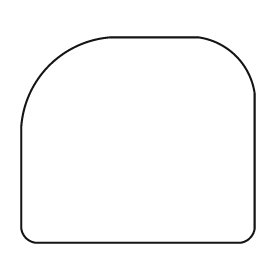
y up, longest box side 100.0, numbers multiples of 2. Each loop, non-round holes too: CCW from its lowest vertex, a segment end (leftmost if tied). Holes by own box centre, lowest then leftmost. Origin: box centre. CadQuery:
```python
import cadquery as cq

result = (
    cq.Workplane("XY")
    .moveTo(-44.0, -44.0)
    .lineTo(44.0, -44.0)
    .threePointArc((48.0, -42.0), (50.0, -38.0))
    .lineTo(50.0, 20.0)
    .threePointArc((42.0, 36.0), (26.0, 44.0))
    .lineTo(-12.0, 44.0)
    .threePointArc((-38.0, 32.0), (-50.0, 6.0))
    .lineTo(-50.0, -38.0)
    .threePointArc((-48.0, -42.0), (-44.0, -44.0))
    .close()
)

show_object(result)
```